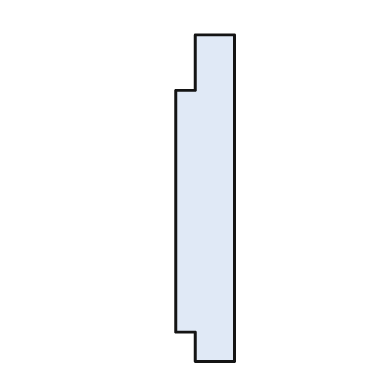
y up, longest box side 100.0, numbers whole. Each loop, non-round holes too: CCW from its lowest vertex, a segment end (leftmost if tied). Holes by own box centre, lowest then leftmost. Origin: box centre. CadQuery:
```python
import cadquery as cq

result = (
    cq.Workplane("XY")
    .moveTo(-3.0, -50.0)
    .lineTo(9.0, -50.0)
    .lineTo(9.0, 50.0)
    .lineTo(-3.0, 50.0)
    .lineTo(-3.0, 33.0)
    .lineTo(-9.0, 33.0)
    .lineTo(-9.0, -41.0)
    .lineTo(-3.0, -41.0)
    .close()
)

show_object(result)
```